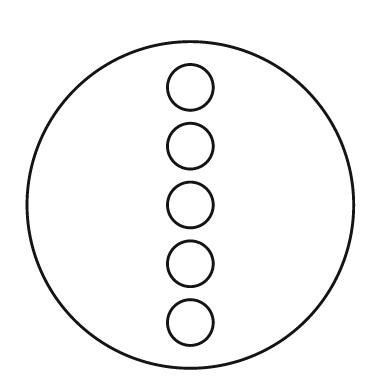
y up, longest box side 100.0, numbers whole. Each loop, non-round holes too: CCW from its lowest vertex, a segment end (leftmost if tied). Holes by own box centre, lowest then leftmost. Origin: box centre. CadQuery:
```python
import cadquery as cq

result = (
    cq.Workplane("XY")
    .moveTo(0.0, 0.0)
    .circle(50.0)
    .moveTo(0.0, -36.0)
    .circle(7.0)
    .moveTo(0.0, -18.0)
    .circle(7.0)
    .moveTo(0.0, 0.0)
    .circle(7.0)
    .moveTo(0.0, 18.0)
    .circle(7.0)
    .moveTo(0.0, 36.0)
    .circle(7.0)
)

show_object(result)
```